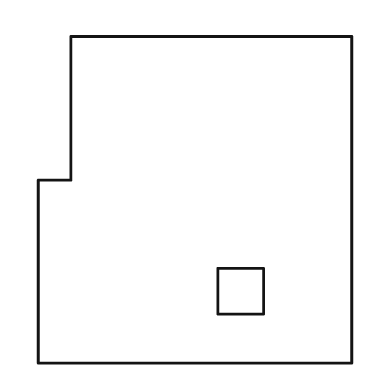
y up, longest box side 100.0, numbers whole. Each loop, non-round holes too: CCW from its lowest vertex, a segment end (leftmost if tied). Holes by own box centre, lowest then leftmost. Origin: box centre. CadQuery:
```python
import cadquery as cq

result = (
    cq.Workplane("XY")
    .moveTo(-48.0, -50.0)
    .lineTo(48.0, -50.0)
    .lineTo(48.0, 50.0)
    .lineTo(-38.0, 50.0)
    .lineTo(-38.0, 6.0)
    .lineTo(-48.0, 6.0)
    .close()
    .moveTo(7.0, -35.0)
    .lineTo(21.0, -35.0)
    .lineTo(21.0, -21.0)
    .lineTo(7.0, -21.0)
    .close()
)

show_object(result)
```